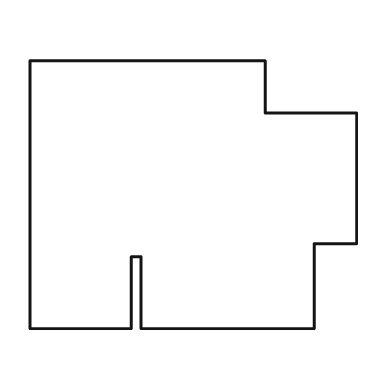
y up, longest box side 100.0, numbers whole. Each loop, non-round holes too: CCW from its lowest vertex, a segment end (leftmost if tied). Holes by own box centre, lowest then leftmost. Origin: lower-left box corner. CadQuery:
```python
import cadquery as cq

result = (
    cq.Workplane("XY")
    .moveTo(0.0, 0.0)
    .lineTo(31.0, 0.0)
    .lineTo(31.0, 22.0)
    .lineTo(34.0, 22.0)
    .lineTo(34.0, 0.0)
    .lineTo(87.0, 0.0)
    .lineTo(87.0, 26.0)
    .lineTo(100.0, 26.0)
    .lineTo(100.0, 66.0)
    .lineTo(72.0, 66.0)
    .lineTo(72.0, 82.0)
    .lineTo(0.0, 82.0)
    .close()
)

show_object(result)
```